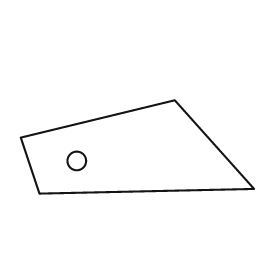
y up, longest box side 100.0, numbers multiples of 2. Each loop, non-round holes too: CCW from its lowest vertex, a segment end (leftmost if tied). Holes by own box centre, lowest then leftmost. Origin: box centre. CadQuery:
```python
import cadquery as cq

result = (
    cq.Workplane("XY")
    .moveTo(-42.0, -20.0)
    .lineTo(50.0, -18.0)
    .lineTo(16.0, 20.0)
    .lineTo(-50.0, 4.0)
    .close()
    .moveTo(-26.0, -6.0)
    .circle(4.0)
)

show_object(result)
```